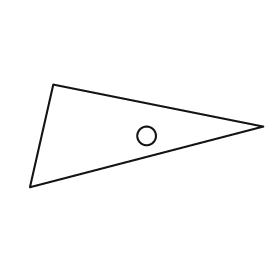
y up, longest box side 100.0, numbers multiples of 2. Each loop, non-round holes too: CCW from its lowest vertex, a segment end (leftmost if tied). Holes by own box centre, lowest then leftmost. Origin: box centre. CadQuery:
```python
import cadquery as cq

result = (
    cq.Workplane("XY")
    .moveTo(-50.0, -22.0)
    .lineTo(50.0, 4.0)
    .lineTo(-40.0, 22.0)
    .close()
    .moveTo(0.0, 0.0)
    .circle(4.0)
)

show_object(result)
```